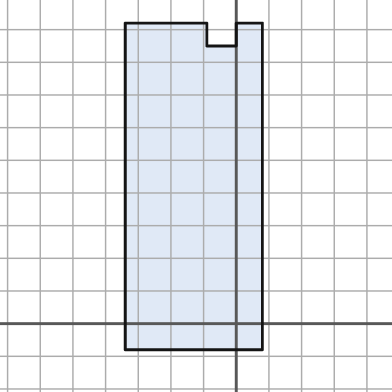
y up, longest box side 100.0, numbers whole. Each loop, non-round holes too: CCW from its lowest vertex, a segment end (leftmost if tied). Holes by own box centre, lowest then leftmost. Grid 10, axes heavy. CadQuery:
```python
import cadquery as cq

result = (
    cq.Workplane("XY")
    .moveTo(-34.0, -8.0)
    .lineTo(8.0, -8.0)
    .lineTo(8.0, 92.0)
    .lineTo(0.0, 92.0)
    .lineTo(0.0, 85.0)
    .lineTo(-9.0, 85.0)
    .lineTo(-9.0, 92.0)
    .lineTo(-34.0, 92.0)
    .close()
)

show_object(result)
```